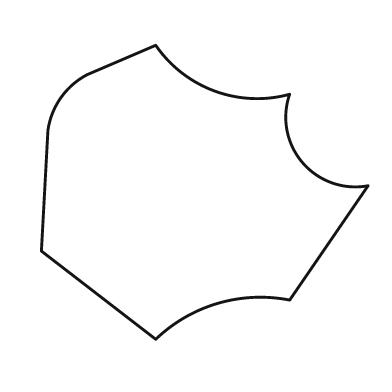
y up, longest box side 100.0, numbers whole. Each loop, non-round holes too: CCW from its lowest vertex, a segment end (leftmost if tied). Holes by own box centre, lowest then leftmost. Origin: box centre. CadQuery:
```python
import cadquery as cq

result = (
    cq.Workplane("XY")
    .moveTo(-15.0, -45.0)
    .threePointArc((4.0, -34.0), (26.0, -33.0))
    .lineTo(50.0, 2.0)
    .threePointArc((30.0, 9.0), (26.0, 30.0))
    .threePointArc((3.0, 31.0), (-15.0, 45.0))
    .lineTo(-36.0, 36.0)
    .threePointArc((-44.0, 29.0), (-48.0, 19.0))
    .lineTo(-50.0, -18.0)
    .close()
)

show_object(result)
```